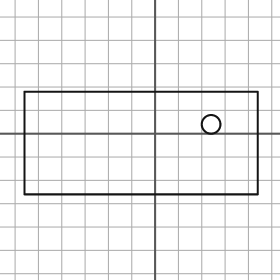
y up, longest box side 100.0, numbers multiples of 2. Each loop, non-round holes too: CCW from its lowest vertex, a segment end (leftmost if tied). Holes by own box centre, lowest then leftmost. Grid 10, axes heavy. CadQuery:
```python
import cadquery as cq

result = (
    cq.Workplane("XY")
    .moveTo(-56.0, -26.0)
    .lineTo(44.0, -26.0)
    .lineTo(44.0, 18.0)
    .lineTo(-56.0, 18.0)
    .close()
    .moveTo(24.0, 4.0)
    .circle(4.0)
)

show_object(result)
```